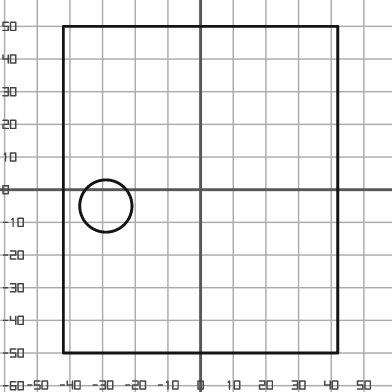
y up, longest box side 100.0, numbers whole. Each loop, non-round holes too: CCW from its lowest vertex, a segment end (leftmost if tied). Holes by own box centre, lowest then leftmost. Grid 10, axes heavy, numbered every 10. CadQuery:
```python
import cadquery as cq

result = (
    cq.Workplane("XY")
    .moveTo(-42.0, -50.0)
    .lineTo(42.0, -50.0)
    .lineTo(42.0, 50.0)
    .lineTo(-42.0, 50.0)
    .close()
    .moveTo(-29.0, -5.0)
    .circle(8.0)
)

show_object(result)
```